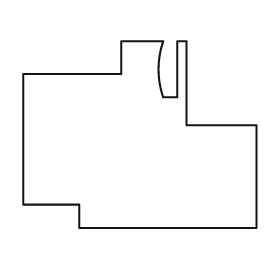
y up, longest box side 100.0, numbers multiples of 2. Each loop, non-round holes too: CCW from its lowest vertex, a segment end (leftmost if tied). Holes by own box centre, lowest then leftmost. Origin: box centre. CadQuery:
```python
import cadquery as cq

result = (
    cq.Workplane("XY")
    .moveTo(-26.0, -40.0)
    .lineTo(50.0, -40.0)
    .lineTo(50.0, 4.0)
    .lineTo(20.0, 4.0)
    .lineTo(20.0, 40.0)
    .lineTo(16.0, 40.0)
    .lineTo(16.0, 16.0)
    .lineTo(10.0, 16.0)
    .threePointArc((8.0, 28.0), (10.0, 40.0))
    .lineTo(-8.0, 40.0)
    .lineTo(-8.0, 26.0)
    .lineTo(-50.0, 26.0)
    .lineTo(-50.0, -30.0)
    .lineTo(-26.0, -30.0)
    .close()
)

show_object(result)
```